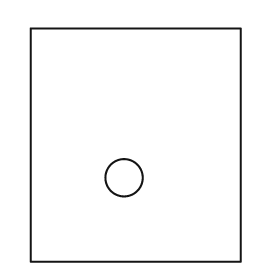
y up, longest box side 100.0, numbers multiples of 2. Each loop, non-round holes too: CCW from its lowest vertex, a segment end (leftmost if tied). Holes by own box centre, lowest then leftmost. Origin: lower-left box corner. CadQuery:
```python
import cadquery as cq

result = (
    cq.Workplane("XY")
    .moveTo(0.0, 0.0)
    .lineTo(90.0, 0.0)
    .lineTo(90.0, 100.0)
    .lineTo(0.0, 100.0)
    .close()
    .moveTo(40.0, 36.0)
    .circle(8.0)
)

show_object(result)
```